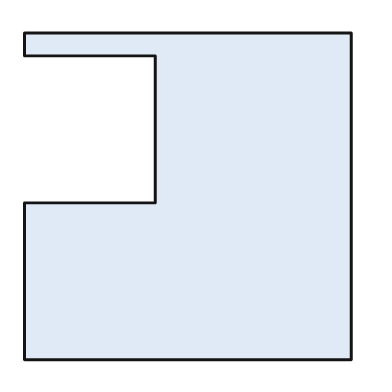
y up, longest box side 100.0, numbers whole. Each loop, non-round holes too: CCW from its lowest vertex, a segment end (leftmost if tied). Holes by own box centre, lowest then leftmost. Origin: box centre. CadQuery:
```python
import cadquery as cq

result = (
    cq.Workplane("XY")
    .moveTo(-50.0, -50.0)
    .lineTo(50.0, -50.0)
    .lineTo(50.0, 50.0)
    .lineTo(-50.0, 50.0)
    .lineTo(-50.0, 43.0)
    .lineTo(-10.0, 43.0)
    .lineTo(-10.0, -2.0)
    .lineTo(-50.0, -2.0)
    .close()
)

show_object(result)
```